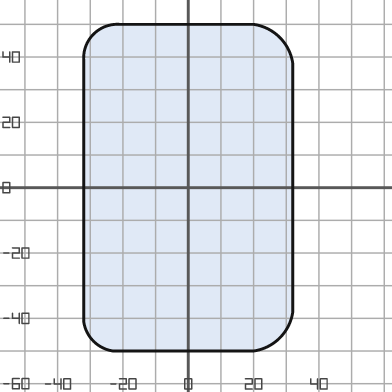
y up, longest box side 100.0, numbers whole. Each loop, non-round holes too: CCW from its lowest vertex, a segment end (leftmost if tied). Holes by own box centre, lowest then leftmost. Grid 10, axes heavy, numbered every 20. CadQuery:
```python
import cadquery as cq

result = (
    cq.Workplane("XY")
    .moveTo(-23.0, -50.0)
    .lineTo(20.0, -50.0)
    .threePointArc((28.0, -46.0), (32.0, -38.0))
    .lineTo(32.0, 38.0)
    .threePointArc((28.0, 46.0), (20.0, 50.0))
    .lineTo(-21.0, 50.0)
    .threePointArc((-29.0, 47.0), (-32.0, 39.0))
    .lineTo(-32.0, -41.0)
    .threePointArc((-29.0, -47.0), (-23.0, -50.0))
    .close()
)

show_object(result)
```